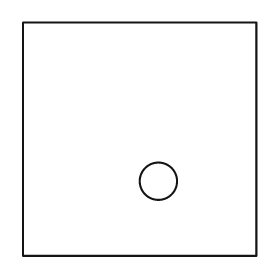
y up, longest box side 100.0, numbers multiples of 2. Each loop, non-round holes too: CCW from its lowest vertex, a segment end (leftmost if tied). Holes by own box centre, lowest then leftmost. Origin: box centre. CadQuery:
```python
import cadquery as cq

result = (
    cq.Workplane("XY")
    .moveTo(-50.0, -50.0)
    .lineTo(50.0, -50.0)
    .lineTo(50.0, 50.0)
    .lineTo(-50.0, 50.0)
    .close()
    .moveTo(8.0, -18.0)
    .circle(8.0)
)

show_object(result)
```